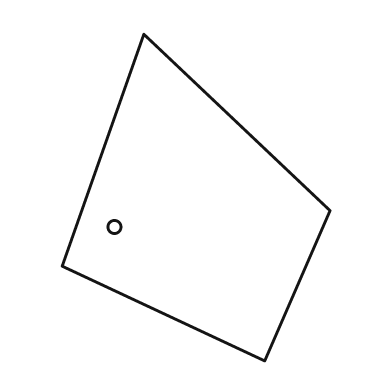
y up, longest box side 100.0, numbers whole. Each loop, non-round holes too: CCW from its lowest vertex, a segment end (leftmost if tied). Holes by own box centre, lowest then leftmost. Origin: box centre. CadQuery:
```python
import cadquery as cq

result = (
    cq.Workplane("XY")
    .moveTo(21.0, -50.0)
    .lineTo(41.0, -4.0)
    .lineTo(-16.0, 50.0)
    .lineTo(-41.0, -21.0)
    .close()
    .moveTo(-25.0, -9.0)
    .circle(2.0)
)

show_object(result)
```